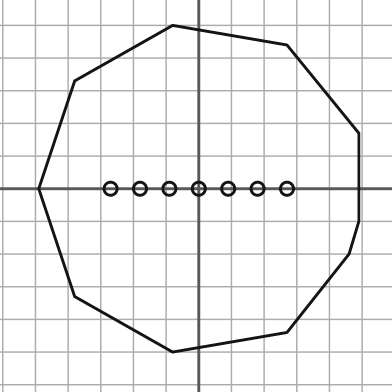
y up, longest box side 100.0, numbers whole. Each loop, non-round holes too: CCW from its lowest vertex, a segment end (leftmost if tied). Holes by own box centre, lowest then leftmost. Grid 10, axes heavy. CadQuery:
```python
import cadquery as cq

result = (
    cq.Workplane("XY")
    .moveTo(-8.0, -50.0)
    .lineTo(27.0, -44.0)
    .lineTo(46.0, -20.0)
    .lineTo(49.0, -10.0)
    .lineTo(49.0, 17.0)
    .lineTo(27.0, 44.0)
    .lineTo(-8.0, 50.0)
    .lineTo(-38.0, 33.0)
    .lineTo(-49.0, 0.0)
    .lineTo(-38.0, -33.0)
    .close()
    .moveTo(-27.0, 0.0)
    .circle(2.0)
    .moveTo(-18.0, 0.0)
    .circle(2.0)
    .moveTo(-9.0, 0.0)
    .circle(2.0)
    .moveTo(0.0, 0.0)
    .circle(2.0)
    .moveTo(9.0, 0.0)
    .circle(2.0)
    .moveTo(18.0, 0.0)
    .circle(2.0)
    .moveTo(27.0, 0.0)
    .circle(2.0)
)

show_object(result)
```